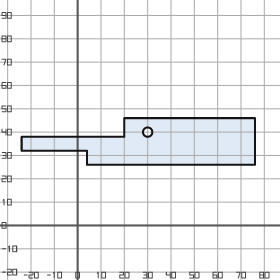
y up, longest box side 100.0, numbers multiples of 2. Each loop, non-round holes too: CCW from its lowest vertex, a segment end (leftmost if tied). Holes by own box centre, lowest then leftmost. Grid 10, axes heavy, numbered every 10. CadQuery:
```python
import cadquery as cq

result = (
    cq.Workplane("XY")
    .moveTo(4.0, 26.0)
    .lineTo(76.0, 26.0)
    .lineTo(76.0, 46.0)
    .lineTo(20.0, 46.0)
    .lineTo(20.0, 38.0)
    .lineTo(-24.0, 38.0)
    .lineTo(-24.0, 32.0)
    .lineTo(4.0, 32.0)
    .close()
    .moveTo(30.0, 40.0)
    .circle(2.0)
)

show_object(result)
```